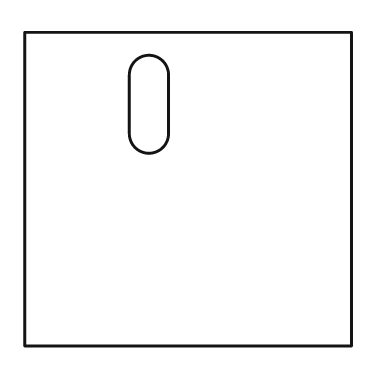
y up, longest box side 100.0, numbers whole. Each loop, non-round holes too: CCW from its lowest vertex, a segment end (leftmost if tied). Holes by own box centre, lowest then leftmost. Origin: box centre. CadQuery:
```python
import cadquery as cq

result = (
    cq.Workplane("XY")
    .moveTo(-50.0, -48.0)
    .lineTo(50.0, -48.0)
    .lineTo(50.0, 48.0)
    .lineTo(-50.0, 48.0)
    .close()
    .moveTo(-18.0, 17.0)
    .threePointArc((-12.0, 11.0), (-6.0, 17.0))
    .lineTo(-6.0, 35.0)
    .threePointArc((-12.0, 41.0), (-18.0, 35.0))
    .close()
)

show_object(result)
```